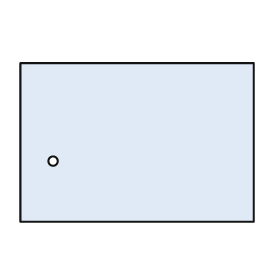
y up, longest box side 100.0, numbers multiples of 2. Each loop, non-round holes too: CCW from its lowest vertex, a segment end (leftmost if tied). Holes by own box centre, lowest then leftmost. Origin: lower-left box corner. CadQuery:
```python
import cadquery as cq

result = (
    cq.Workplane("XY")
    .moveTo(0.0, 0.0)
    .lineTo(100.0, 0.0)
    .lineTo(100.0, 68.0)
    .lineTo(0.0, 68.0)
    .close()
    .moveTo(14.0, 26.0)
    .circle(2.0)
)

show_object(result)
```